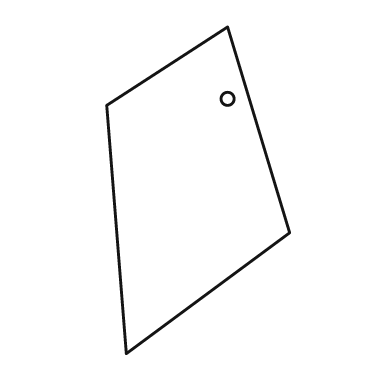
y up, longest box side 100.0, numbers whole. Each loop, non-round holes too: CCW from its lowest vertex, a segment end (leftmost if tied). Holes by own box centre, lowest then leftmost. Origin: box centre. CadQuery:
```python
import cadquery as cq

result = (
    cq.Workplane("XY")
    .moveTo(-22.0, -50.0)
    .lineTo(28.0, -13.0)
    .lineTo(9.0, 50.0)
    .lineTo(-28.0, 26.0)
    .close()
    .moveTo(9.0, 28.0)
    .circle(2.0)
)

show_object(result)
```